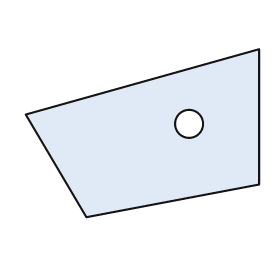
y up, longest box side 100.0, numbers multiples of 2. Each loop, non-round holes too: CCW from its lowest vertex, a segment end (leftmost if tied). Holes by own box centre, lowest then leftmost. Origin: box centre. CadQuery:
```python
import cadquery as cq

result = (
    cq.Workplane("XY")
    .moveTo(-24.0, -36.0)
    .lineTo(50.0, -22.0)
    .lineTo(50.0, 36.0)
    .lineTo(-50.0, 8.0)
    .close()
    .moveTo(20.0, 4.0)
    .circle(6.0)
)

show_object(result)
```